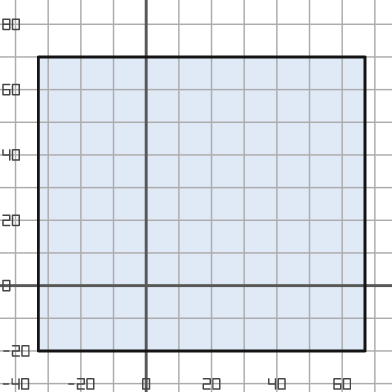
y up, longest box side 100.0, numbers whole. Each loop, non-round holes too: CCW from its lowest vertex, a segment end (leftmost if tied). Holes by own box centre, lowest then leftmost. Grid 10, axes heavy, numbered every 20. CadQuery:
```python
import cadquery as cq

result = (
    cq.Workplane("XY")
    .moveTo(-33.0, -20.0)
    .lineTo(67.0, -20.0)
    .lineTo(67.0, 70.0)
    .lineTo(-33.0, 70.0)
    .close()
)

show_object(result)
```